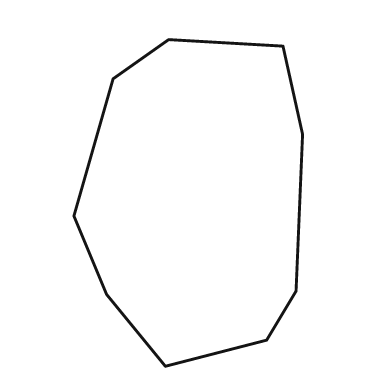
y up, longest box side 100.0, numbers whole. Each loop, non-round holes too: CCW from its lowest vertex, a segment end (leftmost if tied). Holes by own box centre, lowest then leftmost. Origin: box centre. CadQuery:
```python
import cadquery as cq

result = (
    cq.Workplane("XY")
    .moveTo(-7.0, -50.0)
    .lineTo(24.0, -42.0)
    .lineTo(33.0, -27.0)
    .lineTo(35.0, 21.0)
    .lineTo(29.0, 48.0)
    .lineTo(-6.0, 50.0)
    .lineTo(-23.0, 38.0)
    .lineTo(-35.0, -4.0)
    .lineTo(-25.0, -28.0)
    .close()
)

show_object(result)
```